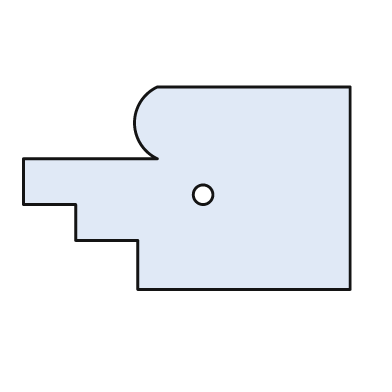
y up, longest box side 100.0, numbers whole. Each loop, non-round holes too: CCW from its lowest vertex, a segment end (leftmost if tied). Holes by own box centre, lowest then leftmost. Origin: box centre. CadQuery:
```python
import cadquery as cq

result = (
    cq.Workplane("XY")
    .moveTo(-15.0, -31.0)
    .lineTo(50.0, -31.0)
    .lineTo(50.0, 31.0)
    .lineTo(-9.0, 31.0)
    .threePointArc((-16.0, 20.0), (-9.0, 9.0))
    .lineTo(-50.0, 9.0)
    .lineTo(-50.0, -5.0)
    .lineTo(-34.0, -5.0)
    .lineTo(-34.0, -16.0)
    .lineTo(-15.0, -16.0)
    .close()
    .moveTo(5.0, -2.0)
    .circle(3.0)
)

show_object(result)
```